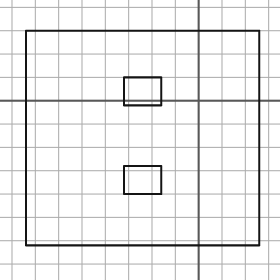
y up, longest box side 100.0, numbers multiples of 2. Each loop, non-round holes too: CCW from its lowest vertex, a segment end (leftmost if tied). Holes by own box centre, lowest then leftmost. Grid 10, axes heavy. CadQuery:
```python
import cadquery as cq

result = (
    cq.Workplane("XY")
    .moveTo(-74.0, -62.0)
    .lineTo(26.0, -62.0)
    .lineTo(26.0, 30.0)
    .lineTo(-74.0, 30.0)
    .close()
    .moveTo(-32.0, -40.0)
    .lineTo(-16.0, -40.0)
    .lineTo(-16.0, -28.0)
    .lineTo(-32.0, -28.0)
    .close()
    .moveTo(-32.0, -2.0)
    .lineTo(-16.0, -2.0)
    .lineTo(-16.0, 10.0)
    .lineTo(-32.0, 10.0)
    .close()
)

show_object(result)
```